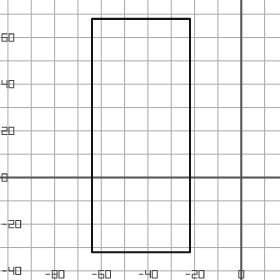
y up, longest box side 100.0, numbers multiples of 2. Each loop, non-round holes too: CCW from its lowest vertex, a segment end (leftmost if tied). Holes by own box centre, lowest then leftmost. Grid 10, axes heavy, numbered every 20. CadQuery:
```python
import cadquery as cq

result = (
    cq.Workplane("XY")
    .moveTo(-64.0, -32.0)
    .lineTo(-22.0, -32.0)
    .lineTo(-22.0, 68.0)
    .lineTo(-64.0, 68.0)
    .close()
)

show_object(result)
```